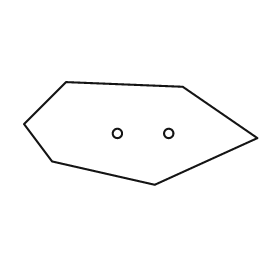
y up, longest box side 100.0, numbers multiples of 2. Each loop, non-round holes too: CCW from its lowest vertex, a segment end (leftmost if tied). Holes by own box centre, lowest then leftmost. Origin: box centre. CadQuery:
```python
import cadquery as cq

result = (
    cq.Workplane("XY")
    .moveTo(6.0, -22.0)
    .lineTo(50.0, -2.0)
    .lineTo(18.0, 20.0)
    .lineTo(-32.0, 22.0)
    .lineTo(-50.0, 4.0)
    .lineTo(-38.0, -12.0)
    .close()
    .moveTo(-10.0, 0.0)
    .circle(2.0)
    .moveTo(12.0, 0.0)
    .circle(2.0)
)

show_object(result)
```